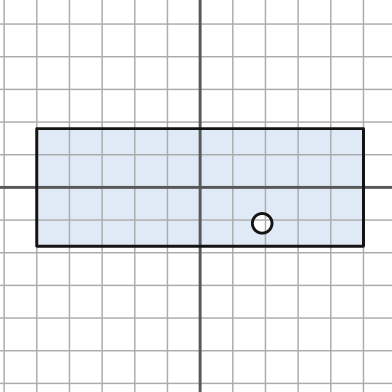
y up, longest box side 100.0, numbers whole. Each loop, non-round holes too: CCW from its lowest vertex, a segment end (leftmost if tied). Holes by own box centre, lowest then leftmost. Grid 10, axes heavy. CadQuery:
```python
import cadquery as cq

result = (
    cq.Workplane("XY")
    .moveTo(-50.0, -18.0)
    .lineTo(50.0, -18.0)
    .lineTo(50.0, 18.0)
    .lineTo(-50.0, 18.0)
    .close()
    .moveTo(19.0, -11.0)
    .circle(3.0)
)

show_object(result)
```